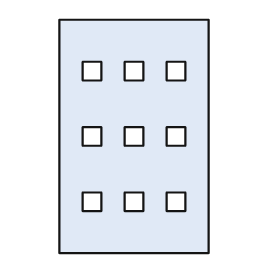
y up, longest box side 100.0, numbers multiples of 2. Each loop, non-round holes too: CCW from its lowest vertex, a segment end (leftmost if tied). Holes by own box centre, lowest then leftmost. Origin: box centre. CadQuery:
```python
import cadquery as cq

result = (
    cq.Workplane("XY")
    .moveTo(-32.0, -50.0)
    .lineTo(32.0, -50.0)
    .lineTo(32.0, 50.0)
    .lineTo(-32.0, 50.0)
    .close()
    .moveTo(-22.0, -32.0)
    .lineTo(-14.0, -32.0)
    .lineTo(-14.0, -24.0)
    .lineTo(-22.0, -24.0)
    .close()
    .moveTo(-4.0, -32.0)
    .lineTo(4.0, -32.0)
    .lineTo(4.0, -24.0)
    .lineTo(-4.0, -24.0)
    .close()
    .moveTo(14.0, -32.0)
    .lineTo(22.0, -32.0)
    .lineTo(22.0, -24.0)
    .lineTo(14.0, -24.0)
    .close()
    .moveTo(-22.0, -4.0)
    .lineTo(-14.0, -4.0)
    .lineTo(-14.0, 4.0)
    .lineTo(-22.0, 4.0)
    .close()
    .moveTo(-4.0, -4.0)
    .lineTo(4.0, -4.0)
    .lineTo(4.0, 4.0)
    .lineTo(-4.0, 4.0)
    .close()
    .moveTo(14.0, -4.0)
    .lineTo(22.0, -4.0)
    .lineTo(22.0, 4.0)
    .lineTo(14.0, 4.0)
    .close()
    .moveTo(-22.0, 24.0)
    .lineTo(-14.0, 24.0)
    .lineTo(-14.0, 32.0)
    .lineTo(-22.0, 32.0)
    .close()
    .moveTo(-4.0, 24.0)
    .lineTo(4.0, 24.0)
    .lineTo(4.0, 32.0)
    .lineTo(-4.0, 32.0)
    .close()
    .moveTo(14.0, 24.0)
    .lineTo(22.0, 24.0)
    .lineTo(22.0, 32.0)
    .lineTo(14.0, 32.0)
    .close()
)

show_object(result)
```